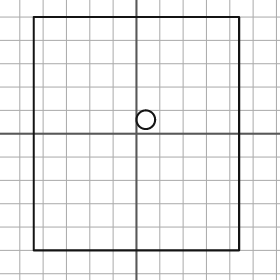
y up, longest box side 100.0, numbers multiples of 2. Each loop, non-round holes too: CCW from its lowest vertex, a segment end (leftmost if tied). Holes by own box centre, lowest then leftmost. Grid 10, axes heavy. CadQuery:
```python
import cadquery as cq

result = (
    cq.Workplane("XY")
    .moveTo(-44.0, -50.0)
    .lineTo(44.0, -50.0)
    .lineTo(44.0, 50.0)
    .lineTo(-44.0, 50.0)
    .close()
    .moveTo(4.0, 6.0)
    .circle(4.0)
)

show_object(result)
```